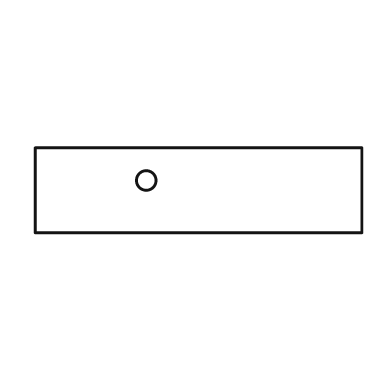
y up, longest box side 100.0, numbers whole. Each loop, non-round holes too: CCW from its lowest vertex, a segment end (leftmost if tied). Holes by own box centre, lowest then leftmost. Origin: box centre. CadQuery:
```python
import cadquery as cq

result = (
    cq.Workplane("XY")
    .moveTo(-50.0, -13.0)
    .lineTo(50.0, -13.0)
    .lineTo(50.0, 13.0)
    .lineTo(-50.0, 13.0)
    .close()
    .moveTo(-16.0, 3.0)
    .circle(3.0)
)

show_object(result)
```